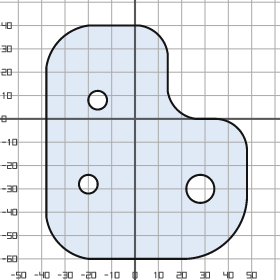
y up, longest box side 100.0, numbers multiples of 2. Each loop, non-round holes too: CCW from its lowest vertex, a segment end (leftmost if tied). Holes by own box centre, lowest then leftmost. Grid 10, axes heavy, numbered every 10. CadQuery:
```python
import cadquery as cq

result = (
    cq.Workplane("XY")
    .moveTo(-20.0, -60.0)
    .lineTo(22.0, -60.0)
    .threePointArc((40.0, -52.0), (48.0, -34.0))
    .lineTo(48.0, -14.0)
    .threePointArc((44.0, -4.0), (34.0, 0.0))
    .lineTo(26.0, 0.0)
    .threePointArc((18.0, 4.0), (14.0, 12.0))
    .lineTo(14.0, 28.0)
    .threePointArc((10.0, 36.0), (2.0, 40.0))
    .lineTo(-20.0, 40.0)
    .threePointArc((-32.0, 34.0), (-38.0, 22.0))
    .lineTo(-38.0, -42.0)
    .threePointArc((-32.0, -54.0), (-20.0, -60.0))
    .close()
    .moveTo(28.0, -30.0)
    .circle(6.0)
    .moveTo(-20.0, -28.0)
    .circle(4.0)
    .moveTo(-16.0, 8.0)
    .circle(4.0)
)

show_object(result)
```